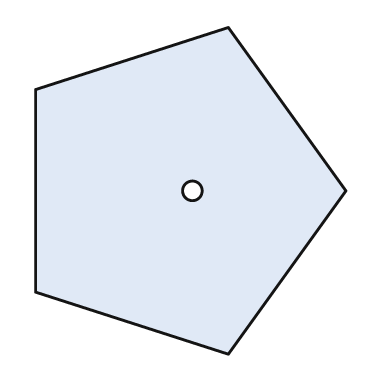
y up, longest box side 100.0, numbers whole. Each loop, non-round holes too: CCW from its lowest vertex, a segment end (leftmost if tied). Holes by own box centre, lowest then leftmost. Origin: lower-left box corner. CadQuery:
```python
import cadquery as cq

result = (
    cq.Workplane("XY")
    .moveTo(59.0, 0.0)
    .lineTo(95.0, 50.0)
    .lineTo(59.0, 100.0)
    .lineTo(0.0, 81.0)
    .lineTo(0.0, 19.0)
    .close()
    .moveTo(48.0, 50.0)
    .circle(3.0)
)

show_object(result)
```